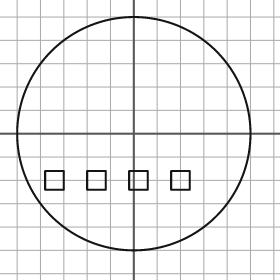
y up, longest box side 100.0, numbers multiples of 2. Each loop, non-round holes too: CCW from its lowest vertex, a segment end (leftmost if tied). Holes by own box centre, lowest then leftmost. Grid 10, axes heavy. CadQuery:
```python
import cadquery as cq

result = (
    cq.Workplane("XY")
    .moveTo(0.0, 0.0)
    .circle(50.0)
    .moveTo(-38.0, -24.0)
    .lineTo(-30.0, -24.0)
    .lineTo(-30.0, -16.0)
    .lineTo(-38.0, -16.0)
    .close()
    .moveTo(-20.0, -24.0)
    .lineTo(-12.0, -24.0)
    .lineTo(-12.0, -16.0)
    .lineTo(-20.0, -16.0)
    .close()
    .moveTo(-2.0, -24.0)
    .lineTo(6.0, -24.0)
    .lineTo(6.0, -16.0)
    .lineTo(-2.0, -16.0)
    .close()
    .moveTo(16.0, -24.0)
    .lineTo(24.0, -24.0)
    .lineTo(24.0, -16.0)
    .lineTo(16.0, -16.0)
    .close()
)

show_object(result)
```